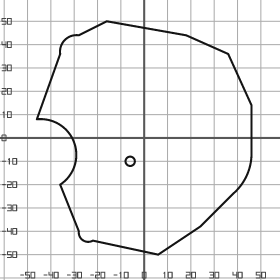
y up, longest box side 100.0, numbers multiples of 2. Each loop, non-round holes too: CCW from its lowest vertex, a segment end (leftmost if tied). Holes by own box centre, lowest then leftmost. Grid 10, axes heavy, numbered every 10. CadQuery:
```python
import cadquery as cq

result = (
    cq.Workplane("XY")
    .moveTo(6.0, -50.0)
    .lineTo(24.0, -38.0)
    .lineTo(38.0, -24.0)
    .threePointArc((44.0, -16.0), (46.0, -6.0))
    .lineTo(46.0, 14.0)
    .lineTo(36.0, 36.0)
    .lineTo(18.0, 44.0)
    .lineTo(-16.0, 50.0)
    .lineTo(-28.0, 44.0)
    .threePointArc((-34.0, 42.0), (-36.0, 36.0))
    .lineTo(-46.0, 8.0)
    .threePointArc((-30.0, -2.0), (-36.0, -20.0))
    .lineTo(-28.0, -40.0)
    .threePointArc((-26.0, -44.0), (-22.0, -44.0))
    .close()
    .moveTo(-6.0, -10.0)
    .circle(2.0)
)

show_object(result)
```